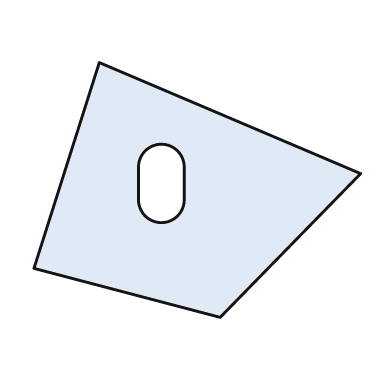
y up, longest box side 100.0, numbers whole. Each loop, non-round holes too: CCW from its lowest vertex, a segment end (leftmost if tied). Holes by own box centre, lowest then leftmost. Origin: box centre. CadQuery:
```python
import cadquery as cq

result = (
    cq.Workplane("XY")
    .moveTo(7.0, -39.0)
    .lineTo(50.0, 5.0)
    .lineTo(-30.0, 39.0)
    .lineTo(-50.0, -24.0)
    .close()
    .moveTo(-18.0, -3.0)
    .threePointArc((-11.0, -10.0), (-4.0, -3.0))
    .lineTo(-4.0, 7.0)
    .threePointArc((-11.0, 14.0), (-18.0, 7.0))
    .close()
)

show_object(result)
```